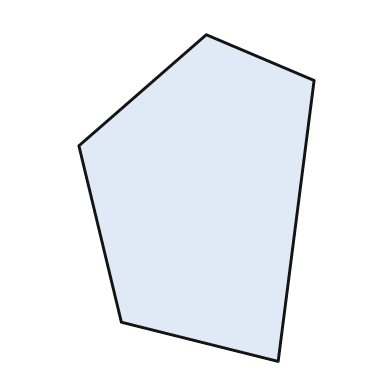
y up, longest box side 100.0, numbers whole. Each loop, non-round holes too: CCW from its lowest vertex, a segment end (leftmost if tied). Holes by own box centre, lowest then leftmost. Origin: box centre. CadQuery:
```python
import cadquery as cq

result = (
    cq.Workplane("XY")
    .moveTo(25.0, -50.0)
    .lineTo(36.0, 36.0)
    .lineTo(3.0, 50.0)
    .lineTo(-36.0, 16.0)
    .lineTo(-23.0, -38.0)
    .close()
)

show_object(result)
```